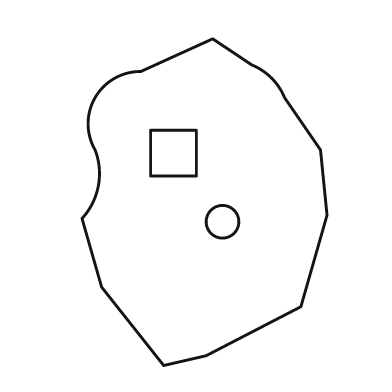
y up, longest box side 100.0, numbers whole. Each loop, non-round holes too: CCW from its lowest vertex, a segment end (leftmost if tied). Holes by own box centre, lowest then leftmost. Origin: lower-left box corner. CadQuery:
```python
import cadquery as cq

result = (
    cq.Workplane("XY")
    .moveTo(25.0, 0.0)
    .lineTo(38.0, 3.0)
    .lineTo(67.0, 18.0)
    .lineTo(75.0, 46.0)
    .lineTo(73.0, 66.0)
    .lineTo(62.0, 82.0)
    .threePointArc((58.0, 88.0), (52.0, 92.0))
    .lineTo(40.0, 100.0)
    .lineTo(18.0, 90.0)
    .threePointArc((4.0, 82.0), (4.0, 66.0))
    .threePointArc((5.0, 55.0), (0.0, 45.0))
    .lineTo(6.0, 24.0)
    .close()
    .moveTo(43.0, 44.0)
    .circle(5.0)
    .moveTo(21.0, 58.0)
    .lineTo(35.0, 58.0)
    .lineTo(35.0, 72.0)
    .lineTo(21.0, 72.0)
    .close()
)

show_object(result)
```